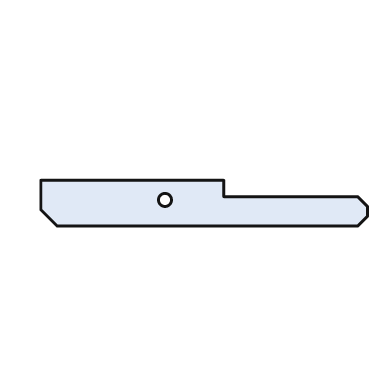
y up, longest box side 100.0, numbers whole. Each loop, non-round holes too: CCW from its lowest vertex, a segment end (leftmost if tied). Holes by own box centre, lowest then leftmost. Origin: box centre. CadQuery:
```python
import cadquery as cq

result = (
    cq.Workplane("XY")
    .moveTo(-45.0, -7.0)
    .lineTo(47.0, -7.0)
    .lineTo(50.0, -4.0)
    .lineTo(50.0, -1.0)
    .lineTo(47.0, 2.0)
    .lineTo(6.0, 2.0)
    .lineTo(6.0, 7.0)
    .lineTo(-50.0, 7.0)
    .lineTo(-50.0, -2.0)
    .close()
    .moveTo(-12.0, 1.0)
    .circle(2.0)
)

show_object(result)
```